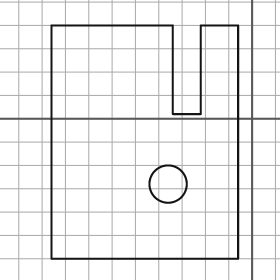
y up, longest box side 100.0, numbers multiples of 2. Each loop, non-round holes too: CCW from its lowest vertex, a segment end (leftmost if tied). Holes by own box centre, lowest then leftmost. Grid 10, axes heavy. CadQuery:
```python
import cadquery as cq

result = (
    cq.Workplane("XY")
    .moveTo(-86.0, -60.0)
    .lineTo(-6.0, -60.0)
    .lineTo(-6.0, 40.0)
    .lineTo(-22.0, 40.0)
    .lineTo(-22.0, 2.0)
    .lineTo(-34.0, 2.0)
    .lineTo(-34.0, 40.0)
    .lineTo(-86.0, 40.0)
    .close()
    .moveTo(-36.0, -28.0)
    .circle(8.0)
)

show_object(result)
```